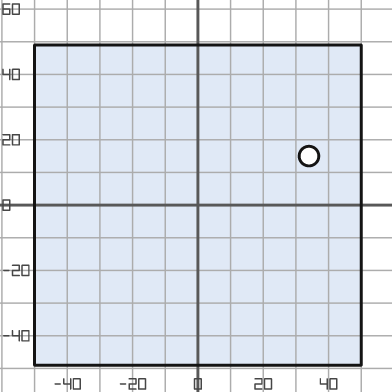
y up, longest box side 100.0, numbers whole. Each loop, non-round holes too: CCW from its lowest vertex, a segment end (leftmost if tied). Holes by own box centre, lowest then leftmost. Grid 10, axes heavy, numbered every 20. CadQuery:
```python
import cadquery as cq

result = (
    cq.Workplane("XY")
    .moveTo(-50.0, -49.0)
    .lineTo(50.0, -49.0)
    .lineTo(50.0, 49.0)
    .lineTo(-50.0, 49.0)
    .close()
    .moveTo(34.0, 15.0)
    .circle(3.0)
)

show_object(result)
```